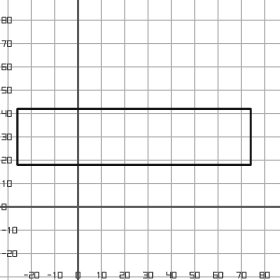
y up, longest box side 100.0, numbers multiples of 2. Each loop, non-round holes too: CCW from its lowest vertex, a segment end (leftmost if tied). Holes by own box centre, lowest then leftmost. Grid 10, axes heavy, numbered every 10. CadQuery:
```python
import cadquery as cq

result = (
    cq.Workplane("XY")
    .moveTo(-26.0, 18.0)
    .lineTo(74.0, 18.0)
    .lineTo(74.0, 42.0)
    .lineTo(-26.0, 42.0)
    .close()
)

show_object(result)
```